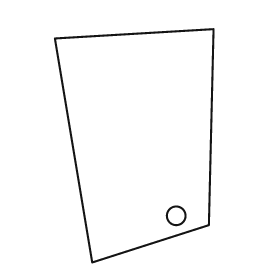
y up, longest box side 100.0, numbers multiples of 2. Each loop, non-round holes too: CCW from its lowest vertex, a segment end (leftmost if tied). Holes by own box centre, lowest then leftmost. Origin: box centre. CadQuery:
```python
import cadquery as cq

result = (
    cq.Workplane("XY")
    .moveTo(-18.0, -50.0)
    .lineTo(32.0, -34.0)
    .lineTo(34.0, 50.0)
    .lineTo(-34.0, 46.0)
    .close()
    .moveTo(18.0, -30.0)
    .circle(4.0)
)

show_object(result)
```